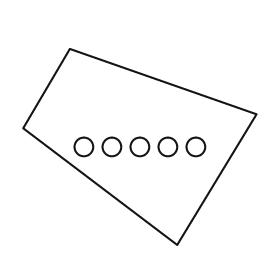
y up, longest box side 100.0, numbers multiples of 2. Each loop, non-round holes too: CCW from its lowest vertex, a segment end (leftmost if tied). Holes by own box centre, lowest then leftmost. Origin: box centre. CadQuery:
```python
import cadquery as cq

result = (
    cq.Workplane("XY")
    .moveTo(16.0, -42.0)
    .lineTo(50.0, 14.0)
    .lineTo(-30.0, 42.0)
    .lineTo(-50.0, 8.0)
    .close()
    .moveTo(-24.0, 0.0)
    .circle(4.0)
    .moveTo(-12.0, 0.0)
    .circle(4.0)
    .moveTo(0.0, 0.0)
    .circle(4.0)
    .moveTo(12.0, 0.0)
    .circle(4.0)
    .moveTo(24.0, 0.0)
    .circle(4.0)
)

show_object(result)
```